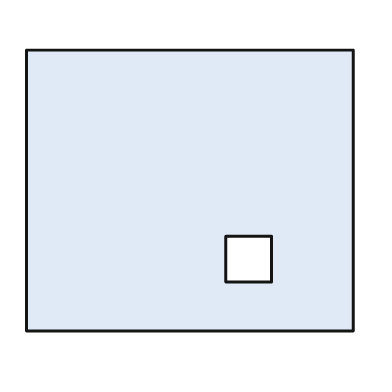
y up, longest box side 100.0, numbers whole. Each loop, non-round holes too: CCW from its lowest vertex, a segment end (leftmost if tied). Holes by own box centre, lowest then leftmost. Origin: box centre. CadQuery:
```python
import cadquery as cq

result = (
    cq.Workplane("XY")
    .moveTo(-50.0, -43.0)
    .lineTo(50.0, -43.0)
    .lineTo(50.0, 43.0)
    .lineTo(-50.0, 43.0)
    .close()
    .moveTo(11.0, -28.0)
    .lineTo(25.0, -28.0)
    .lineTo(25.0, -14.0)
    .lineTo(11.0, -14.0)
    .close()
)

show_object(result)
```